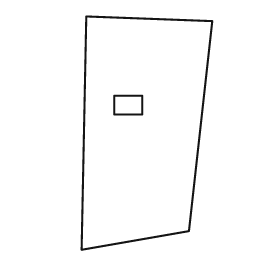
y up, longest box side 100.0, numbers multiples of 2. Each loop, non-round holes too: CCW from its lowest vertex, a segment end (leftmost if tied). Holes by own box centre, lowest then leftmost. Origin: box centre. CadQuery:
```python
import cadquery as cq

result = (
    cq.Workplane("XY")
    .moveTo(-28.0, -50.0)
    .lineTo(18.0, -42.0)
    .lineTo(28.0, 48.0)
    .lineTo(-26.0, 50.0)
    .close()
    .moveTo(-14.0, 8.0)
    .lineTo(-2.0, 8.0)
    .lineTo(-2.0, 16.0)
    .lineTo(-14.0, 16.0)
    .close()
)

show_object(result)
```